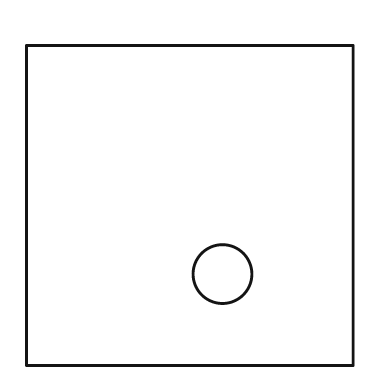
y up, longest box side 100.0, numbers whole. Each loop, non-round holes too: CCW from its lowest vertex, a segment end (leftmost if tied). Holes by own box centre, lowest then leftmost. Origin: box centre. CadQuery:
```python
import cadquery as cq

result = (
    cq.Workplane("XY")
    .moveTo(-50.0, -49.0)
    .lineTo(50.0, -49.0)
    .lineTo(50.0, 49.0)
    .lineTo(-50.0, 49.0)
    .close()
    .moveTo(10.0, -21.0)
    .circle(9.0)
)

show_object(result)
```